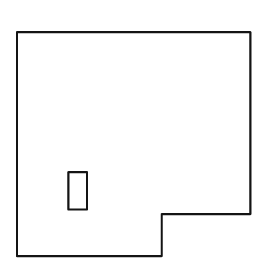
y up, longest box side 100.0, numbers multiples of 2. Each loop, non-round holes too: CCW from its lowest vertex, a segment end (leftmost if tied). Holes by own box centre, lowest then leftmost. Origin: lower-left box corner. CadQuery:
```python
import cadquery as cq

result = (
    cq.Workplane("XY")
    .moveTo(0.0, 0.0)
    .lineTo(62.0, 0.0)
    .lineTo(62.0, 18.0)
    .lineTo(100.0, 18.0)
    .lineTo(100.0, 96.0)
    .lineTo(0.0, 96.0)
    .close()
    .moveTo(22.0, 20.0)
    .lineTo(30.0, 20.0)
    .lineTo(30.0, 36.0)
    .lineTo(22.0, 36.0)
    .close()
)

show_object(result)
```